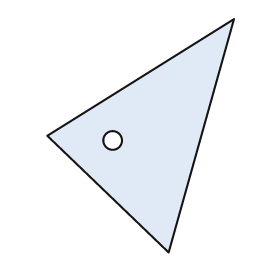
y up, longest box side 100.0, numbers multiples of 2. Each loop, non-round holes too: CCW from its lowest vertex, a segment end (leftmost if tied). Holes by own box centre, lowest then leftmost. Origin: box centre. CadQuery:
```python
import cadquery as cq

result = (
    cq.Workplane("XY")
    .moveTo(12.0, -50.0)
    .lineTo(40.0, 50.0)
    .lineTo(-40.0, 0.0)
    .close()
    .moveTo(-12.0, -2.0)
    .circle(4.0)
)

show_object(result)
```